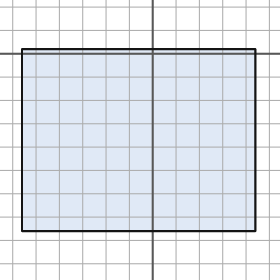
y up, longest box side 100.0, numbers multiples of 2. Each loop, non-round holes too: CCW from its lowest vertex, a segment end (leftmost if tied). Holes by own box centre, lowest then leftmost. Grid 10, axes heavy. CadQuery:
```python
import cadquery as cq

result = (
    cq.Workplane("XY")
    .moveTo(-56.0, -76.0)
    .lineTo(44.0, -76.0)
    .lineTo(44.0, 2.0)
    .lineTo(-56.0, 2.0)
    .close()
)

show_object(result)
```